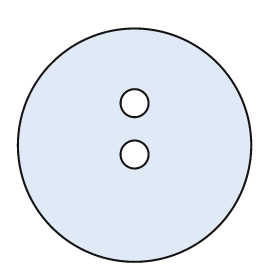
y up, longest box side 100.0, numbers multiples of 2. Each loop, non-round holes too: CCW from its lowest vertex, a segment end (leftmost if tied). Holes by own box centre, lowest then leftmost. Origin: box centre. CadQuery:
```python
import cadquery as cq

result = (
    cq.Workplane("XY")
    .moveTo(0.0, 0.0)
    .circle(50.0)
    .moveTo(0.0, -4.0)
    .circle(6.0)
    .moveTo(0.0, 18.0)
    .circle(6.0)
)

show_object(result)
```